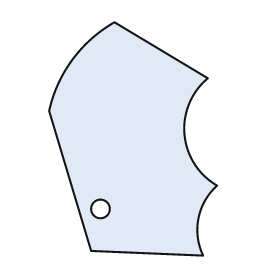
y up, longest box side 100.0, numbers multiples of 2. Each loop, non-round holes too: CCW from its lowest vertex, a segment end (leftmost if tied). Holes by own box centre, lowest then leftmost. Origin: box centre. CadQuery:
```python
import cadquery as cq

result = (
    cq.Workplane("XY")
    .moveTo(30.0, -50.0)
    .threePointArc((28.0, -34.0), (36.0, -20.0))
    .threePointArc((22.0, 2.0), (32.0, 26.0))
    .lineTo(-8.0, 50.0)
    .threePointArc((-26.0, 34.0), (-36.0, 12.0))
    .lineTo(-18.0, -48.0)
    .close()
    .moveTo(-14.0, -30.0)
    .circle(4.0)
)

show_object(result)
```